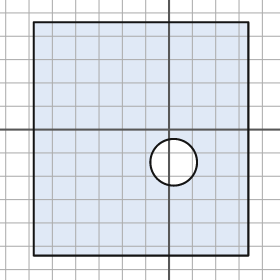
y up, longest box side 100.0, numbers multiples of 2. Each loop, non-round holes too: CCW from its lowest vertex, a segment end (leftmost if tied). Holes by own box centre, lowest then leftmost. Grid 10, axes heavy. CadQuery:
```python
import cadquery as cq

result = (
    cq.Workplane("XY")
    .moveTo(-58.0, -54.0)
    .lineTo(34.0, -54.0)
    .lineTo(34.0, 46.0)
    .lineTo(-58.0, 46.0)
    .close()
    .moveTo(2.0, -14.0)
    .circle(10.0)
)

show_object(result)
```